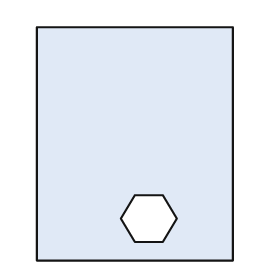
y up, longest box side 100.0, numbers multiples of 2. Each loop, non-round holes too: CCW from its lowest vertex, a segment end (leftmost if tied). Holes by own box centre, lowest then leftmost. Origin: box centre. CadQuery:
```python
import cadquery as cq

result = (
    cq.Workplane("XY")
    .moveTo(-42.0, -50.0)
    .lineTo(42.0, -50.0)
    .lineTo(42.0, 50.0)
    .lineTo(-42.0, 50.0)
    .close()
    .moveTo(0.0, -42.0)
    .lineTo(12.0, -42.0)
    .lineTo(18.0, -32.0)
    .lineTo(12.0, -22.0)
    .lineTo(0.0, -22.0)
    .lineTo(-6.0, -32.0)
    .close()
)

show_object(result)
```